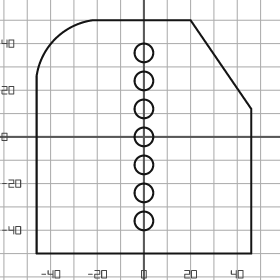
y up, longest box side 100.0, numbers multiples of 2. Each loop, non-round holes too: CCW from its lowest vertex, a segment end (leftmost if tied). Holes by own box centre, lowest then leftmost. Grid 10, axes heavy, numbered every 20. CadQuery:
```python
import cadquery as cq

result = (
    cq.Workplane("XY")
    .moveTo(-46.0, -50.0)
    .lineTo(46.0, -50.0)
    .lineTo(46.0, 12.0)
    .lineTo(20.0, 50.0)
    .lineTo(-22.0, 50.0)
    .threePointArc((-38.0, 42.0), (-46.0, 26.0))
    .close()
    .moveTo(0.0, -36.0)
    .circle(4.0)
    .moveTo(0.0, -24.0)
    .circle(4.0)
    .moveTo(0.0, -12.0)
    .circle(4.0)
    .moveTo(0.0, 0.0)
    .circle(4.0)
    .moveTo(0.0, 12.0)
    .circle(4.0)
    .moveTo(0.0, 24.0)
    .circle(4.0)
    .moveTo(0.0, 36.0)
    .circle(4.0)
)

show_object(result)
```